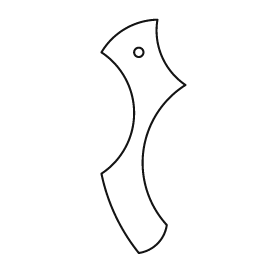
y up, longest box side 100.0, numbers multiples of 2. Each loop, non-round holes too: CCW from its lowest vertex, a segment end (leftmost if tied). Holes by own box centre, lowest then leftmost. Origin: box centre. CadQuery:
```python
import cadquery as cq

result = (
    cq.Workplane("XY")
    .moveTo(-2.0, -50.0)
    .threePointArc((6.0, -46.0), (10.0, -38.0))
    .threePointArc((0.0, -6.0), (18.0, 22.0))
    .threePointArc((8.0, 34.0), (6.0, 50.0))
    .threePointArc((-8.0, 46.0), (-18.0, 36.0))
    .threePointArc((-4.0, 10.0), (-18.0, -16.0))
    .threePointArc((-12.0, -34.0), (-2.0, -50.0))
    .close()
    .moveTo(-2.0, 36.0)
    .circle(2.0)
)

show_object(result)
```